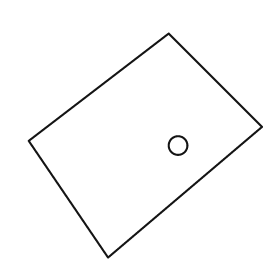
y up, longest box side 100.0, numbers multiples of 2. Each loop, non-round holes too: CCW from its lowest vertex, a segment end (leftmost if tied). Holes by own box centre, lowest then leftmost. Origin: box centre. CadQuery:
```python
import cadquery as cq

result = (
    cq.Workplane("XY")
    .moveTo(-16.0, -48.0)
    .lineTo(50.0, 8.0)
    .lineTo(10.0, 48.0)
    .lineTo(-50.0, 2.0)
    .close()
    .moveTo(14.0, 0.0)
    .circle(4.0)
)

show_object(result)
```